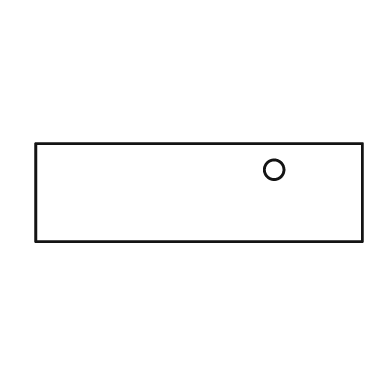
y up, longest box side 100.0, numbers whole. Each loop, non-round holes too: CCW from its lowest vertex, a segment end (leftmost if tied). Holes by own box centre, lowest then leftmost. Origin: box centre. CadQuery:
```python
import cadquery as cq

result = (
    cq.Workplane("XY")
    .moveTo(-50.0, -15.0)
    .lineTo(50.0, -15.0)
    .lineTo(50.0, 15.0)
    .lineTo(-50.0, 15.0)
    .close()
    .moveTo(23.0, 7.0)
    .circle(3.0)
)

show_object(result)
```